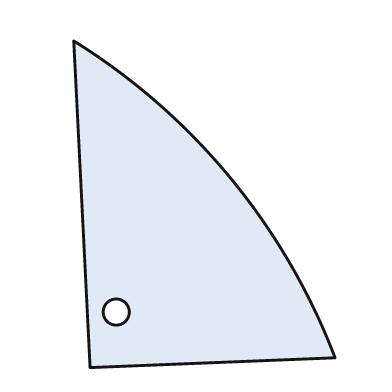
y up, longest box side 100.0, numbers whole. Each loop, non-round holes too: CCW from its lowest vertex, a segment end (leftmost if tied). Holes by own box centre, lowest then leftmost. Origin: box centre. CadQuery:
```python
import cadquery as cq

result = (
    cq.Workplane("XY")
    .moveTo(-35.0, -50.0)
    .lineTo(40.0, -47.0)
    .threePointArc((8.0, 8.0), (-40.0, 50.0))
    .close()
    .moveTo(-27.0, -33.0)
    .circle(4.0)
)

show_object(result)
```